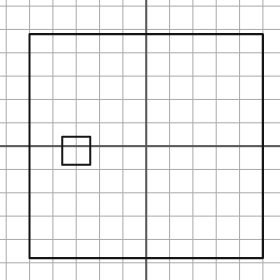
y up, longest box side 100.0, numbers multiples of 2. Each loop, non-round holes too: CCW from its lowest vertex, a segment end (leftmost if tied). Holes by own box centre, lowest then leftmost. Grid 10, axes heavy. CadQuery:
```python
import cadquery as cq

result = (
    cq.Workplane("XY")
    .moveTo(-50.0, -48.0)
    .lineTo(50.0, -48.0)
    .lineTo(50.0, 48.0)
    .lineTo(-50.0, 48.0)
    .close()
    .moveTo(-36.0, -8.0)
    .lineTo(-24.0, -8.0)
    .lineTo(-24.0, 4.0)
    .lineTo(-36.0, 4.0)
    .close()
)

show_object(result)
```